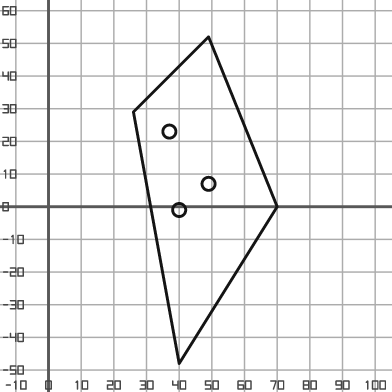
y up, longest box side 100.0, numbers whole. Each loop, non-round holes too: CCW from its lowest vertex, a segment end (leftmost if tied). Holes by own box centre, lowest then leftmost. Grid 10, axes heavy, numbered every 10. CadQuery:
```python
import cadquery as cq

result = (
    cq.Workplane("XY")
    .moveTo(40.0, -48.0)
    .lineTo(70.0, 0.0)
    .lineTo(49.0, 52.0)
    .lineTo(26.0, 29.0)
    .close()
    .moveTo(40.0, -1.0)
    .circle(2.0)
    .moveTo(49.0, 7.0)
    .circle(2.0)
    .moveTo(37.0, 23.0)
    .circle(2.0)
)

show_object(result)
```